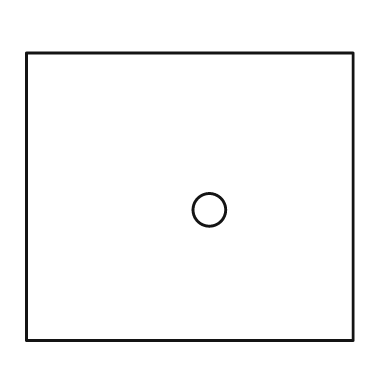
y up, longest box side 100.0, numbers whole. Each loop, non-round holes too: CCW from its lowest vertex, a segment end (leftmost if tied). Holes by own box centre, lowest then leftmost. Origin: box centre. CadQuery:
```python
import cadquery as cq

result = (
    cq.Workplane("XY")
    .moveTo(-50.0, -44.0)
    .lineTo(50.0, -44.0)
    .lineTo(50.0, 44.0)
    .lineTo(-50.0, 44.0)
    .close()
    .moveTo(6.0, -4.0)
    .circle(5.0)
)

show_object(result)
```